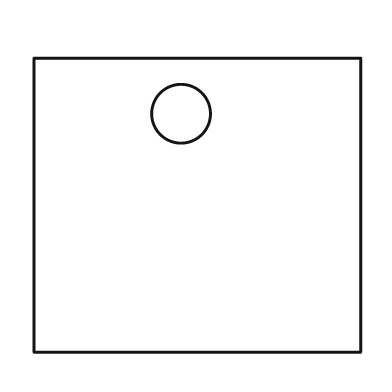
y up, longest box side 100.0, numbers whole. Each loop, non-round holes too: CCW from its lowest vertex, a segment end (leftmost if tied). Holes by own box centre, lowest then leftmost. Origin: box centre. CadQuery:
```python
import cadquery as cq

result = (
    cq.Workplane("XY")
    .moveTo(-50.0, -45.0)
    .lineTo(50.0, -45.0)
    .lineTo(50.0, 45.0)
    .lineTo(-50.0, 45.0)
    .close()
    .moveTo(-5.0, 28.0)
    .circle(9.0)
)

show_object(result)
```